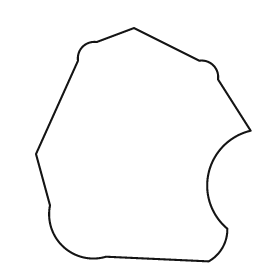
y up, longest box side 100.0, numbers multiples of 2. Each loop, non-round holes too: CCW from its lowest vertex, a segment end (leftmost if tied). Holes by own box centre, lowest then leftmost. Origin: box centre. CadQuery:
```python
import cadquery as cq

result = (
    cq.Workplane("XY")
    .moveTo(28.0, -50.0)
    .threePointArc((34.0, -44.0), (36.0, -36.0))
    .threePointArc((28.0, -12.0), (46.0, 6.0))
    .lineTo(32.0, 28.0)
    .threePointArc((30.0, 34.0), (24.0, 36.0))
    .lineTo(-4.0, 50.0)
    .lineTo(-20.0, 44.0)
    .threePointArc((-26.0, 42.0), (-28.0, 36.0))
    .lineTo(-46.0, -4.0)
    .lineTo(-40.0, -26.0)
    .threePointArc((-34.0, -44.0), (-16.0, -48.0))
    .close()
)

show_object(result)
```